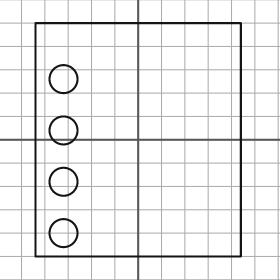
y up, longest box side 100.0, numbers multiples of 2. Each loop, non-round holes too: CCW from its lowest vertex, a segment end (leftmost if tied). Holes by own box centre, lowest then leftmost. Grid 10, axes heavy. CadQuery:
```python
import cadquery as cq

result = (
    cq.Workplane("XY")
    .moveTo(-44.0, -50.0)
    .lineTo(44.0, -50.0)
    .lineTo(44.0, 50.0)
    .lineTo(-44.0, 50.0)
    .close()
    .moveTo(-32.0, -40.0)
    .circle(6.0)
    .moveTo(-32.0, -18.0)
    .circle(6.0)
    .moveTo(-32.0, 4.0)
    .circle(6.0)
    .moveTo(-32.0, 26.0)
    .circle(6.0)
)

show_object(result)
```